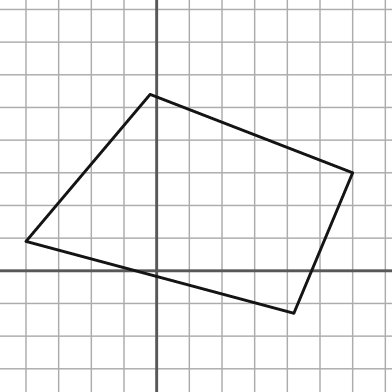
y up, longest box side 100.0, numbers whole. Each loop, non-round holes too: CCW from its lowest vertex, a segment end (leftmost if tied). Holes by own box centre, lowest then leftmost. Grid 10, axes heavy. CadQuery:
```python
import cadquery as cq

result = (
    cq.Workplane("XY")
    .moveTo(42.0, -13.0)
    .lineTo(60.0, 30.0)
    .lineTo(-2.0, 54.0)
    .lineTo(-40.0, 9.0)
    .close()
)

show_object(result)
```